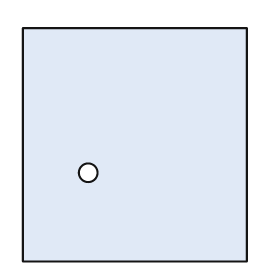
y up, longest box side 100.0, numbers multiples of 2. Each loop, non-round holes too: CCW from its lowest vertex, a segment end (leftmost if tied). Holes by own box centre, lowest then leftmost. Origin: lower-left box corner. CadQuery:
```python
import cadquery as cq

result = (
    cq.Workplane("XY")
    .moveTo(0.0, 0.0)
    .lineTo(96.0, 0.0)
    .lineTo(96.0, 100.0)
    .lineTo(0.0, 100.0)
    .close()
    .moveTo(28.0, 38.0)
    .circle(4.0)
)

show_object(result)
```